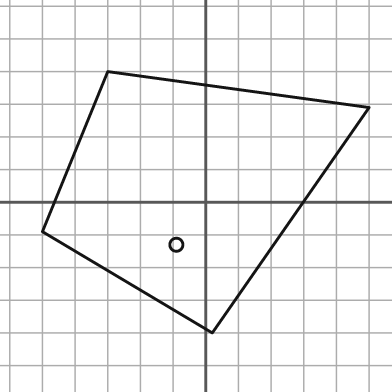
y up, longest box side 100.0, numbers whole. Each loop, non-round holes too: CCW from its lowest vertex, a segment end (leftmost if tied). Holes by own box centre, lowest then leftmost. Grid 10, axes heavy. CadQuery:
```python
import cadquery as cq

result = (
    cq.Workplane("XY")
    .moveTo(2.0, -40.0)
    .lineTo(50.0, 29.0)
    .lineTo(-30.0, 40.0)
    .lineTo(-50.0, -9.0)
    .close()
    .moveTo(-9.0, -13.0)
    .circle(2.0)
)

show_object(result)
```